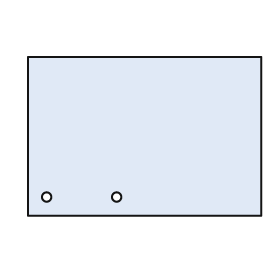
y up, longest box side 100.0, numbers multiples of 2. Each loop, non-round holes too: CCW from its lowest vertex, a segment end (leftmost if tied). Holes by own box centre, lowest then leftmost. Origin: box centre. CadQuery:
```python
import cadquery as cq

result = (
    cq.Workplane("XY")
    .moveTo(-50.0, -34.0)
    .lineTo(50.0, -34.0)
    .lineTo(50.0, 34.0)
    .lineTo(-50.0, 34.0)
    .close()
    .moveTo(-42.0, -26.0)
    .circle(2.0)
    .moveTo(-12.0, -26.0)
    .circle(2.0)
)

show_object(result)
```